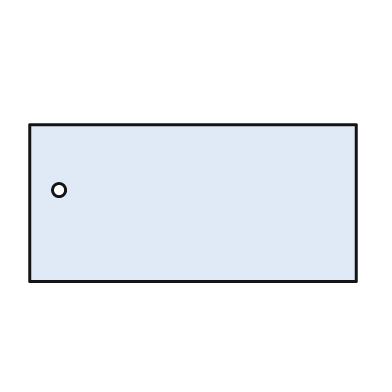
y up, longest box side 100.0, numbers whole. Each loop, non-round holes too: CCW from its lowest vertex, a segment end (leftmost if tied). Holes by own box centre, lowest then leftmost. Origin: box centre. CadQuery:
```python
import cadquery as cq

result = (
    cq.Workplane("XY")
    .moveTo(-50.0, -24.0)
    .lineTo(50.0, -24.0)
    .lineTo(50.0, 24.0)
    .lineTo(-50.0, 24.0)
    .close()
    .moveTo(-41.0, 4.0)
    .circle(2.0)
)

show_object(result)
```